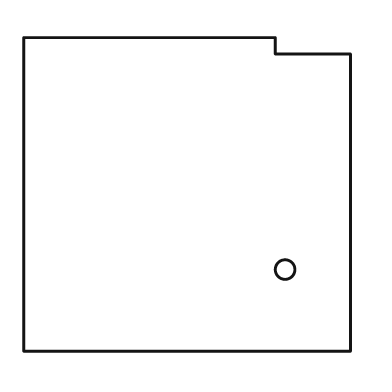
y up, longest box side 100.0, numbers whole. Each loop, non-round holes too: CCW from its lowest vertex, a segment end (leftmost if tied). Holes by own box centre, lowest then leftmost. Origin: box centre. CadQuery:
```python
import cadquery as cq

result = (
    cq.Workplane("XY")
    .moveTo(-50.0, -48.0)
    .lineTo(50.0, -48.0)
    .lineTo(50.0, 43.0)
    .lineTo(27.0, 43.0)
    .lineTo(27.0, 48.0)
    .lineTo(-50.0, 48.0)
    .close()
    .moveTo(30.0, -23.0)
    .circle(3.0)
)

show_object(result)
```